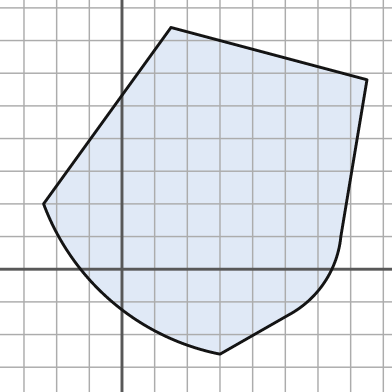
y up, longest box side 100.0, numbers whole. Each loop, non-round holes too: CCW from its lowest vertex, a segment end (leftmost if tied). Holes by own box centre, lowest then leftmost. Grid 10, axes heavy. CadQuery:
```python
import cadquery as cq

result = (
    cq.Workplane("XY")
    .moveTo(30.0, -26.0)
    .lineTo(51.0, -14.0)
    .threePointArc((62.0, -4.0), (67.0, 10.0))
    .lineTo(75.0, 58.0)
    .lineTo(15.0, 74.0)
    .lineTo(-24.0, 20.0)
    .threePointArc((-3.0, -10.0), (30.0, -26.0))
    .close()
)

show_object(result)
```